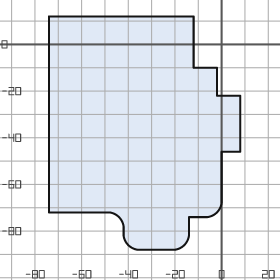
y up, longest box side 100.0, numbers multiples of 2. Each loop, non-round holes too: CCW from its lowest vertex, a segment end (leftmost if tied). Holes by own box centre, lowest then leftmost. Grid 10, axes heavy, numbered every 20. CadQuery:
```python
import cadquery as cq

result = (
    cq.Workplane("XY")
    .moveTo(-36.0, -88.0)
    .lineTo(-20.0, -88.0)
    .threePointArc((-16.0, -86.0), (-14.0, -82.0))
    .lineTo(-14.0, -74.0)
    .lineTo(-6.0, -74.0)
    .threePointArc((-2.0, -72.0), (0.0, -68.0))
    .lineTo(0.0, -46.0)
    .lineTo(8.0, -46.0)
    .lineTo(8.0, -22.0)
    .lineTo(-2.0, -22.0)
    .lineTo(-2.0, -10.0)
    .lineTo(-12.0, -10.0)
    .lineTo(-12.0, 12.0)
    .lineTo(-74.0, 12.0)
    .lineTo(-74.0, -72.0)
    .lineTo(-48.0, -72.0)
    .threePointArc((-44.0, -74.0), (-42.0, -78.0))
    .lineTo(-42.0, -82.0)
    .threePointArc((-40.0, -86.0), (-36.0, -88.0))
    .close()
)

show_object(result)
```